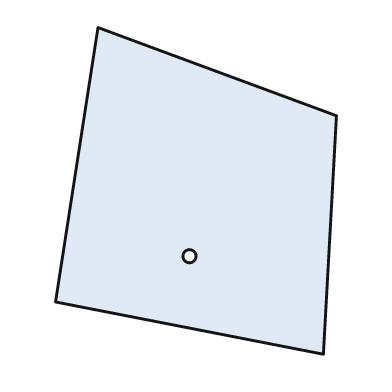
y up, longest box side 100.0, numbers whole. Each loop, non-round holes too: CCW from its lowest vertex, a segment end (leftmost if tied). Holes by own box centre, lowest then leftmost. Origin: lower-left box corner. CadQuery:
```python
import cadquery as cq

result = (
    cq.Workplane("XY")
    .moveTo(82.0, 0.0)
    .lineTo(86.0, 73.0)
    .lineTo(13.0, 100.0)
    .lineTo(0.0, 16.0)
    .close()
    .moveTo(41.0, 30.0)
    .circle(2.0)
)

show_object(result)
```